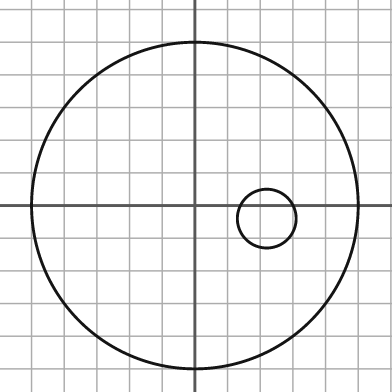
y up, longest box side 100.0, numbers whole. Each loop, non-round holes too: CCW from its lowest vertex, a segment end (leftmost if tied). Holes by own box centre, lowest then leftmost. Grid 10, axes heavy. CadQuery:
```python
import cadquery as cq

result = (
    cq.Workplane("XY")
    .moveTo(0.0, 0.0)
    .circle(50.0)
    .moveTo(22.0, -4.0)
    .circle(9.0)
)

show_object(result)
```